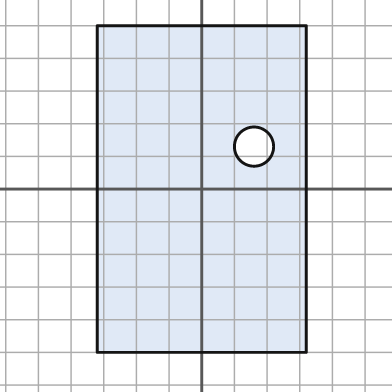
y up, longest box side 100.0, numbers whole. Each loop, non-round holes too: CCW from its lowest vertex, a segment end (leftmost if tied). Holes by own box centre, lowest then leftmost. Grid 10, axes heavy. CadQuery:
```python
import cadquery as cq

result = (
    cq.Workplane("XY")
    .moveTo(-32.0, -50.0)
    .lineTo(32.0, -50.0)
    .lineTo(32.0, 50.0)
    .lineTo(-32.0, 50.0)
    .close()
    .moveTo(16.0, 13.0)
    .circle(6.0)
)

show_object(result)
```